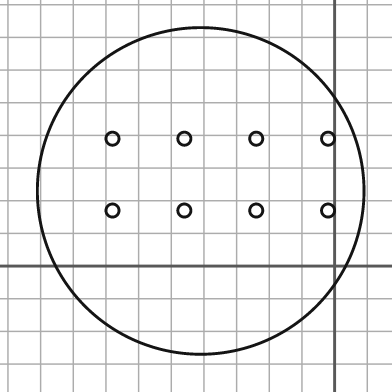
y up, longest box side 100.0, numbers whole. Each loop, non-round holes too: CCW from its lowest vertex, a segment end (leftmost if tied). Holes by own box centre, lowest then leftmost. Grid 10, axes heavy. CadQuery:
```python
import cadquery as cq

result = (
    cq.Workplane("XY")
    .moveTo(-41.0, 23.0)
    .circle(50.0)
    .moveTo(-68.0, 17.0)
    .circle(2.0)
    .moveTo(-46.0, 17.0)
    .circle(2.0)
    .moveTo(-24.0, 17.0)
    .circle(2.0)
    .moveTo(-2.0, 17.0)
    .circle(2.0)
    .moveTo(-68.0, 39.0)
    .circle(2.0)
    .moveTo(-46.0, 39.0)
    .circle(2.0)
    .moveTo(-24.0, 39.0)
    .circle(2.0)
    .moveTo(-2.0, 39.0)
    .circle(2.0)
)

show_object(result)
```